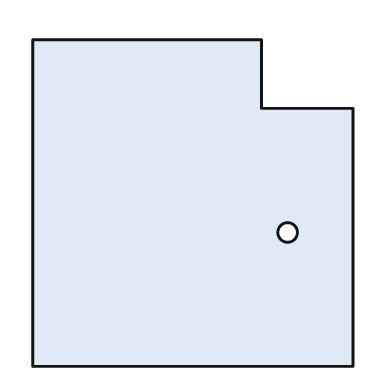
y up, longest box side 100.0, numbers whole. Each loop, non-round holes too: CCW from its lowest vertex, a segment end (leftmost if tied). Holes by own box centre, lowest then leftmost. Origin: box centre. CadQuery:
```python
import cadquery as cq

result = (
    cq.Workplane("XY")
    .moveTo(-49.0, -50.0)
    .lineTo(49.0, -50.0)
    .lineTo(49.0, 29.0)
    .lineTo(21.0, 29.0)
    .lineTo(21.0, 50.0)
    .lineTo(-49.0, 50.0)
    .close()
    .moveTo(29.0, -9.0)
    .circle(3.0)
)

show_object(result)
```